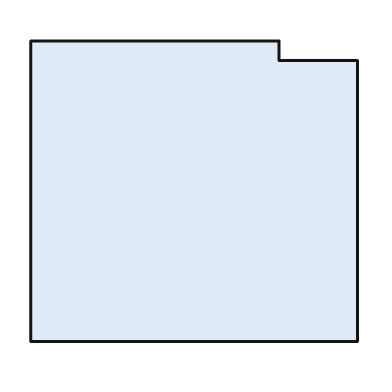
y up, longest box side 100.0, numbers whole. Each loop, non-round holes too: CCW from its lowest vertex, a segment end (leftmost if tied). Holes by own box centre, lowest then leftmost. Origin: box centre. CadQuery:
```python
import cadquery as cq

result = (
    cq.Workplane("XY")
    .moveTo(-50.0, -46.0)
    .lineTo(50.0, -46.0)
    .lineTo(50.0, 40.0)
    .lineTo(26.0, 40.0)
    .lineTo(26.0, 46.0)
    .lineTo(-50.0, 46.0)
    .close()
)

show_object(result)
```